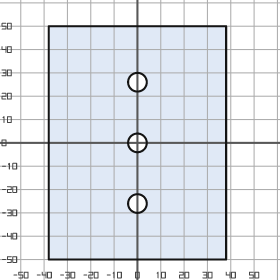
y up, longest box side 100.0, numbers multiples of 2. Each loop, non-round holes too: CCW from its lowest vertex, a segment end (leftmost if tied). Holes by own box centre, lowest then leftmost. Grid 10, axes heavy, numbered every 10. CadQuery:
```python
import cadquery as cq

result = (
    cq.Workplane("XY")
    .moveTo(-38.0, -50.0)
    .lineTo(38.0, -50.0)
    .lineTo(38.0, 50.0)
    .lineTo(-38.0, 50.0)
    .close()
    .moveTo(0.0, -26.0)
    .circle(4.0)
    .moveTo(0.0, 0.0)
    .circle(4.0)
    .moveTo(0.0, 26.0)
    .circle(4.0)
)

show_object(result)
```